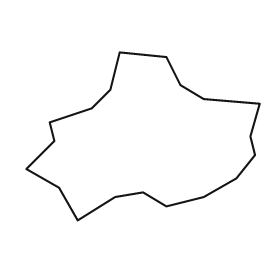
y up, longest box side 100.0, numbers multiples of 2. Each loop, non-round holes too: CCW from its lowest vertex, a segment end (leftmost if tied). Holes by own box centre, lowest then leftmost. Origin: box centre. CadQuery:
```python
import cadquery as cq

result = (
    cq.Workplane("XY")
    .moveTo(-28.0, -36.0)
    .lineTo(-12.0, -26.0)
    .lineTo(0.0, -24.0)
    .lineTo(10.0, -30.0)
    .lineTo(26.0, -26.0)
    .lineTo(40.0, -18.0)
    .lineTo(48.0, -8.0)
    .lineTo(46.0, 0.0)
    .lineTo(50.0, 14.0)
    .lineTo(26.0, 16.0)
    .lineTo(16.0, 22.0)
    .lineTo(10.0, 34.0)
    .lineTo(-10.0, 36.0)
    .lineTo(-14.0, 20.0)
    .lineTo(-22.0, 12.0)
    .lineTo(-40.0, 6.0)
    .lineTo(-38.0, -2.0)
    .lineTo(-50.0, -14.0)
    .lineTo(-36.0, -22.0)
    .close()
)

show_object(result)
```